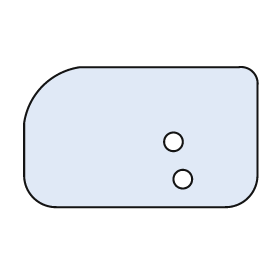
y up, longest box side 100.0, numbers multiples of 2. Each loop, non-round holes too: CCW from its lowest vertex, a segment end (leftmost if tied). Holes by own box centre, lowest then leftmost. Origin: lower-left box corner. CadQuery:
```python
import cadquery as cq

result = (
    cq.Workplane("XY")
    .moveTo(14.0, 0.0)
    .lineTo(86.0, 0.0)
    .threePointArc((96.0, 4.0), (100.0, 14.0))
    .lineTo(100.0, 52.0)
    .threePointArc((98.0, 58.0), (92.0, 60.0))
    .lineTo(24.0, 60.0)
    .threePointArc((8.0, 52.0), (0.0, 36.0))
    .lineTo(0.0, 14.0)
    .threePointArc((4.0, 4.0), (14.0, 0.0))
    .close()
    .moveTo(68.0, 12.0)
    .circle(4.0)
    .moveTo(64.0, 28.0)
    .circle(4.0)
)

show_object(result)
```